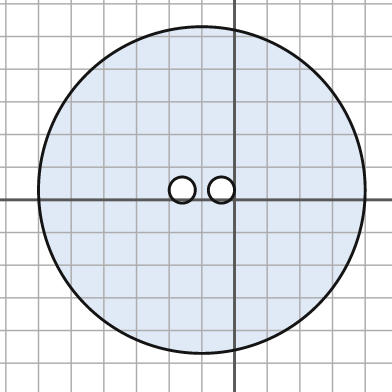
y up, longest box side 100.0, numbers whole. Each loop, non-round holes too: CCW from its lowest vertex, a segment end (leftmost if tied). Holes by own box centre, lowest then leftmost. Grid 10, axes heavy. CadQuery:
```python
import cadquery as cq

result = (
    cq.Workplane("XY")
    .moveTo(-10.0, 3.0)
    .circle(50.0)
    .moveTo(-16.0, 3.0)
    .circle(4.0)
    .moveTo(-4.0, 3.0)
    .circle(4.0)
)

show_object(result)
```